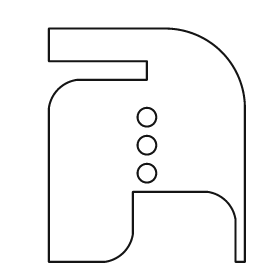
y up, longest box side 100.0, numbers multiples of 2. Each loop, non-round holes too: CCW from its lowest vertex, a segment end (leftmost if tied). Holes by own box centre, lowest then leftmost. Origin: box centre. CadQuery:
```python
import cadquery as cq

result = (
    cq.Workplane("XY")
    .moveTo(-42.0, -50.0)
    .lineTo(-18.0, -50.0)
    .threePointArc((-10.0, -46.0), (-6.0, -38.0))
    .lineTo(-6.0, -20.0)
    .lineTo(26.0, -20.0)
    .threePointArc((34.0, -24.0), (38.0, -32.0))
    .lineTo(38.0, -50.0)
    .lineTo(42.0, -50.0)
    .lineTo(42.0, 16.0)
    .threePointArc((32.0, 40.0), (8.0, 50.0))
    .lineTo(-42.0, 50.0)
    .lineTo(-42.0, 36.0)
    .lineTo(0.0, 36.0)
    .lineTo(0.0, 28.0)
    .lineTo(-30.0, 28.0)
    .threePointArc((-38.0, 24.0), (-42.0, 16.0))
    .close()
    .moveTo(0.0, -12.0)
    .circle(4.0)
    .moveTo(0.0, 0.0)
    .circle(4.0)
    .moveTo(0.0, 12.0)
    .circle(4.0)
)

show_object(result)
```